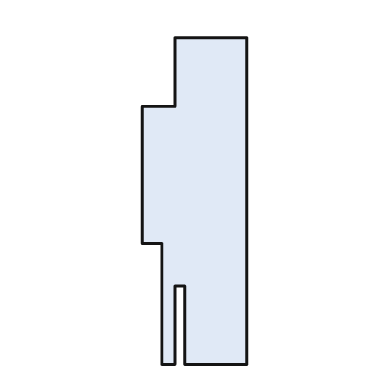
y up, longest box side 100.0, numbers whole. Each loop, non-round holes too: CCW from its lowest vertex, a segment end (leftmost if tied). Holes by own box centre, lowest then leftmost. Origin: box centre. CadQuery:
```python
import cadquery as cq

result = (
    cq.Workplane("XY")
    .moveTo(-10.0, -50.0)
    .lineTo(-6.0, -50.0)
    .lineTo(-6.0, -26.0)
    .lineTo(-3.0, -26.0)
    .lineTo(-3.0, -50.0)
    .lineTo(16.0, -50.0)
    .lineTo(16.0, 50.0)
    .lineTo(-6.0, 50.0)
    .lineTo(-6.0, 29.0)
    .lineTo(-16.0, 29.0)
    .lineTo(-16.0, -13.0)
    .lineTo(-10.0, -13.0)
    .close()
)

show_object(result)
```